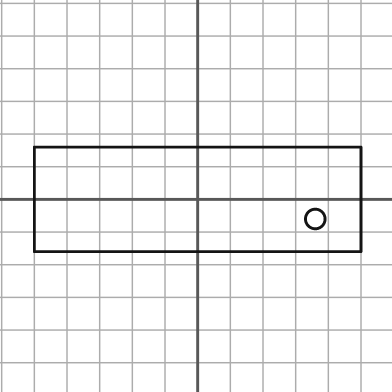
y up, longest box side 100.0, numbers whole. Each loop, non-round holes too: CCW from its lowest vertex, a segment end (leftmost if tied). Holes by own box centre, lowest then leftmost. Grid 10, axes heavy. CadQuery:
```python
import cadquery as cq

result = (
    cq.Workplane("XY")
    .moveTo(-50.0, -16.0)
    .lineTo(50.0, -16.0)
    .lineTo(50.0, 16.0)
    .lineTo(-50.0, 16.0)
    .close()
    .moveTo(36.0, -6.0)
    .circle(3.0)
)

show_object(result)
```